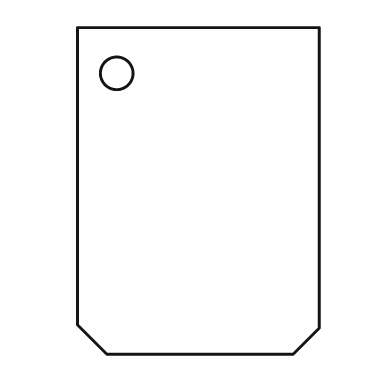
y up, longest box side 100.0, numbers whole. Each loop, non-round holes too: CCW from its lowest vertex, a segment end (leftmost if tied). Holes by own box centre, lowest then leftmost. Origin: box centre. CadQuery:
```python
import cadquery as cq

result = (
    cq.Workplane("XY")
    .moveTo(-28.0, -50.0)
    .lineTo(29.0, -50.0)
    .lineTo(37.0, -42.0)
    .lineTo(37.0, 50.0)
    .lineTo(-37.0, 50.0)
    .lineTo(-37.0, -41.0)
    .close()
    .moveTo(-25.0, 36.0)
    .circle(5.0)
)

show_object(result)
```